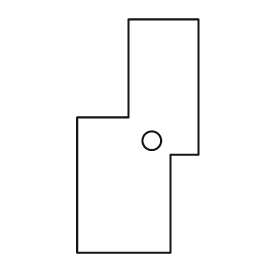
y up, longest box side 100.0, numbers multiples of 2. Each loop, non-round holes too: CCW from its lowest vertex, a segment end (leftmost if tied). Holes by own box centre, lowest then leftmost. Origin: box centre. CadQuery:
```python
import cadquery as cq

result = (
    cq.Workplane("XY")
    .moveTo(-26.0, -50.0)
    .lineTo(14.0, -50.0)
    .lineTo(14.0, -8.0)
    .lineTo(26.0, -8.0)
    .lineTo(26.0, 50.0)
    .lineTo(-4.0, 50.0)
    .lineTo(-4.0, 8.0)
    .lineTo(-26.0, 8.0)
    .close()
    .moveTo(6.0, -2.0)
    .circle(4.0)
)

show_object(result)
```